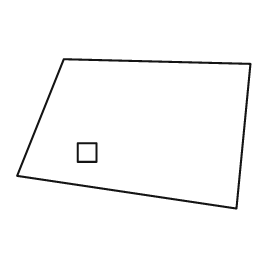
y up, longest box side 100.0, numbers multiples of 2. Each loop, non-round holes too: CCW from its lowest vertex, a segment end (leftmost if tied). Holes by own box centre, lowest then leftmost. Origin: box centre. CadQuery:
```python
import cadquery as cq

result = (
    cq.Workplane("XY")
    .moveTo(44.0, -32.0)
    .lineTo(50.0, 30.0)
    .lineTo(-30.0, 32.0)
    .lineTo(-50.0, -18.0)
    .close()
    .moveTo(-24.0, -12.0)
    .lineTo(-16.0, -12.0)
    .lineTo(-16.0, -4.0)
    .lineTo(-24.0, -4.0)
    .close()
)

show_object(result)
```